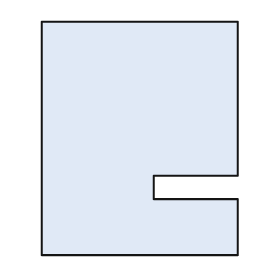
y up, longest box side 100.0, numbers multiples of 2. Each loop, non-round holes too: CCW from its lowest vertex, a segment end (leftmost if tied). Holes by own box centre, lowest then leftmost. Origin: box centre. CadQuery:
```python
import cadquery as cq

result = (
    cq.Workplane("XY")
    .moveTo(-42.0, -50.0)
    .lineTo(42.0, -50.0)
    .lineTo(42.0, -26.0)
    .lineTo(6.0, -26.0)
    .lineTo(6.0, -16.0)
    .lineTo(42.0, -16.0)
    .lineTo(42.0, 50.0)
    .lineTo(-42.0, 50.0)
    .close()
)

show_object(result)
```